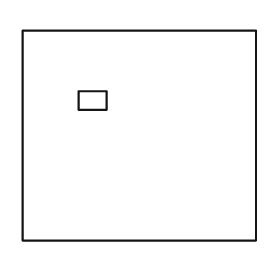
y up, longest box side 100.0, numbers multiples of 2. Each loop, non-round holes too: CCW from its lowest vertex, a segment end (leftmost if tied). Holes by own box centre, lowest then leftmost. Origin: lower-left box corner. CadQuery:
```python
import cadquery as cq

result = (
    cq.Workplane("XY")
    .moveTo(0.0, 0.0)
    .lineTo(100.0, 0.0)
    .lineTo(100.0, 90.0)
    .lineTo(0.0, 90.0)
    .close()
    .moveTo(24.0, 56.0)
    .lineTo(36.0, 56.0)
    .lineTo(36.0, 64.0)
    .lineTo(24.0, 64.0)
    .close()
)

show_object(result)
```